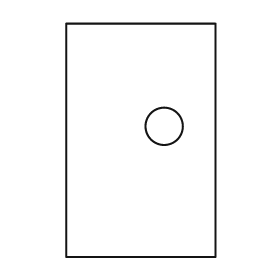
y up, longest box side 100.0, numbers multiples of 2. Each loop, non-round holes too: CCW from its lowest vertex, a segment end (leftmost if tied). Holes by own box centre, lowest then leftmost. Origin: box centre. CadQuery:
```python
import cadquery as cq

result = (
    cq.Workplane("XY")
    .moveTo(-32.0, -50.0)
    .lineTo(32.0, -50.0)
    .lineTo(32.0, 50.0)
    .lineTo(-32.0, 50.0)
    .close()
    .moveTo(10.0, 6.0)
    .circle(8.0)
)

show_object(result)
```